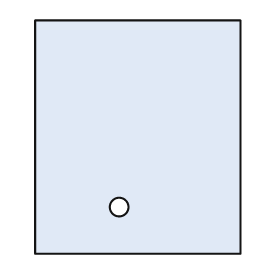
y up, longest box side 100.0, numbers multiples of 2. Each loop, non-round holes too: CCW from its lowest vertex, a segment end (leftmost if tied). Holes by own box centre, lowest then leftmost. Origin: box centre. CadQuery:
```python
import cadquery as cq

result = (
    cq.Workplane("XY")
    .moveTo(-44.0, -50.0)
    .lineTo(44.0, -50.0)
    .lineTo(44.0, 50.0)
    .lineTo(-44.0, 50.0)
    .close()
    .moveTo(-8.0, -30.0)
    .circle(4.0)
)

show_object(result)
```